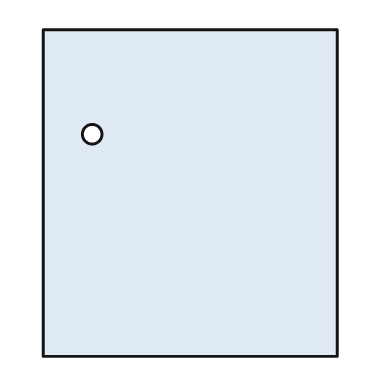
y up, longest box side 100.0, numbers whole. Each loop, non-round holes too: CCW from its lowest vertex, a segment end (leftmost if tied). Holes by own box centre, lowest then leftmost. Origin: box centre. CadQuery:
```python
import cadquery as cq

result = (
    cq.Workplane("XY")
    .moveTo(-45.0, -50.0)
    .lineTo(45.0, -50.0)
    .lineTo(45.0, 50.0)
    .lineTo(-45.0, 50.0)
    .close()
    .moveTo(-30.0, 18.0)
    .circle(3.0)
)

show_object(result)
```